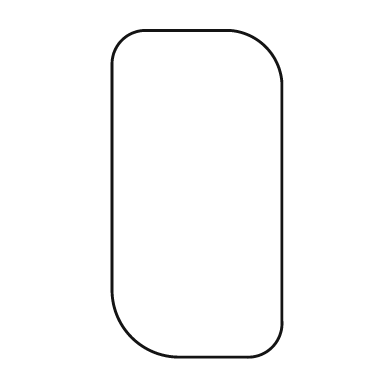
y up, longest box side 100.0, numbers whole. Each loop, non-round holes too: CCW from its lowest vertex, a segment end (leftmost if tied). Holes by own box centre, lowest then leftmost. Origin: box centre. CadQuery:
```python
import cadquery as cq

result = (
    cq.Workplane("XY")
    .moveTo(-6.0, -50.0)
    .lineTo(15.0, -50.0)
    .threePointArc((23.0, -47.0), (26.0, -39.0))
    .lineTo(26.0, 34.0)
    .threePointArc((21.0, 45.0), (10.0, 50.0))
    .lineTo(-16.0, 50.0)
    .threePointArc((-23.0, 47.0), (-26.0, 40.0))
    .lineTo(-26.0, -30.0)
    .threePointArc((-20.0, -44.0), (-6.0, -50.0))
    .close()
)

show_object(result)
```